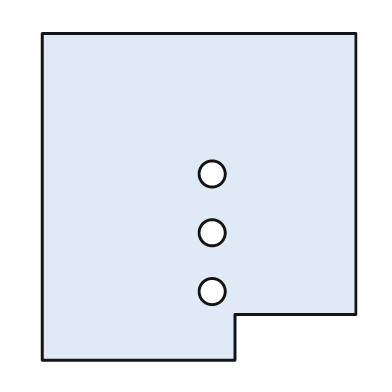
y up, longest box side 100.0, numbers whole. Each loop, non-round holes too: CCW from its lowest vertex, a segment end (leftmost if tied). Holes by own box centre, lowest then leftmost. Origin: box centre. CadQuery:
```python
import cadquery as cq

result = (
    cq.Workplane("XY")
    .moveTo(-48.0, -50.0)
    .lineTo(11.0, -50.0)
    .lineTo(11.0, -36.0)
    .lineTo(48.0, -36.0)
    .lineTo(48.0, 50.0)
    .lineTo(-48.0, 50.0)
    .close()
    .moveTo(4.0, -29.0)
    .circle(4.0)
    .moveTo(4.0, -11.0)
    .circle(4.0)
    .moveTo(4.0, 7.0)
    .circle(4.0)
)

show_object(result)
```